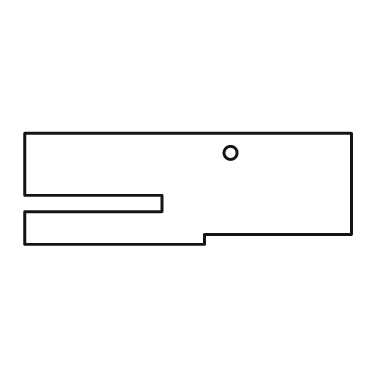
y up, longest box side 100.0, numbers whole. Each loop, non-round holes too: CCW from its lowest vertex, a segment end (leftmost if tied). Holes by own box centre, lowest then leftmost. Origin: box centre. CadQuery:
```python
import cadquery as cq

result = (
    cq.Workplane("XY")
    .moveTo(-50.0, -17.0)
    .lineTo(5.0, -17.0)
    .lineTo(5.0, -14.0)
    .lineTo(50.0, -14.0)
    .lineTo(50.0, 17.0)
    .lineTo(-50.0, 17.0)
    .lineTo(-50.0, -2.0)
    .lineTo(-8.0, -2.0)
    .lineTo(-8.0, -7.0)
    .lineTo(-50.0, -7.0)
    .close()
    .moveTo(13.0, 11.0)
    .circle(2.0)
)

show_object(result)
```